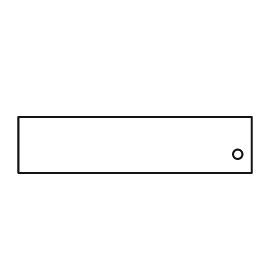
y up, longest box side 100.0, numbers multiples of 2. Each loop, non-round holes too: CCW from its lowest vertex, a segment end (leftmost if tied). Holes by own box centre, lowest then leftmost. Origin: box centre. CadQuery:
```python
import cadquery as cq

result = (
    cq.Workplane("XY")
    .moveTo(-50.0, -12.0)
    .lineTo(50.0, -12.0)
    .lineTo(50.0, 12.0)
    .lineTo(-50.0, 12.0)
    .close()
    .moveTo(44.0, -4.0)
    .circle(2.0)
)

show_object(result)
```